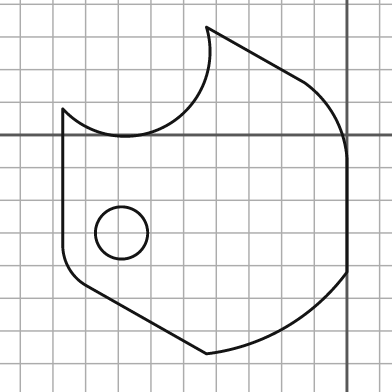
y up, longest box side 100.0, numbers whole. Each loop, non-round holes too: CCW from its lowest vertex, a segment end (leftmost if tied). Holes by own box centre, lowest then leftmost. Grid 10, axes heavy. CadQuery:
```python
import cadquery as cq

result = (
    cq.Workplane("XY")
    .moveTo(-43.0, -67.0)
    .threePointArc((-19.0, -59.0), (0.0, -42.0))
    .lineTo(0.0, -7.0)
    .threePointArc((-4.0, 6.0), (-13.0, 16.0))
    .lineTo(-43.0, 33.0)
    .threePointArc((-55.0, 3.0), (-87.0, 8.0))
    .lineTo(-87.0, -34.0)
    .threePointArc((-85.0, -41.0), (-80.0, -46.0))
    .close()
    .moveTo(-69.0, -30.0)
    .circle(8.0)
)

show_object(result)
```